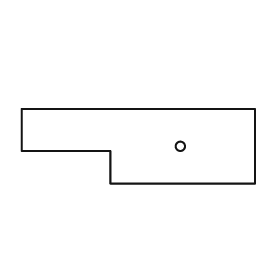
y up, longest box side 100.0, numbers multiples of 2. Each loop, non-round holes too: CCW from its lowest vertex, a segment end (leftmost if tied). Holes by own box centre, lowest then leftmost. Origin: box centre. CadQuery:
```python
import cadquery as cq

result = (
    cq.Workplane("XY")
    .moveTo(-12.0, -16.0)
    .lineTo(50.0, -16.0)
    .lineTo(50.0, 16.0)
    .lineTo(-50.0, 16.0)
    .lineTo(-50.0, -2.0)
    .lineTo(-12.0, -2.0)
    .close()
    .moveTo(18.0, 0.0)
    .circle(2.0)
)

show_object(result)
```